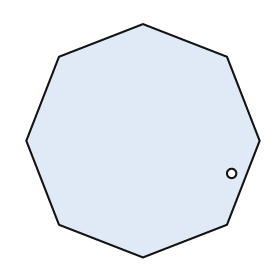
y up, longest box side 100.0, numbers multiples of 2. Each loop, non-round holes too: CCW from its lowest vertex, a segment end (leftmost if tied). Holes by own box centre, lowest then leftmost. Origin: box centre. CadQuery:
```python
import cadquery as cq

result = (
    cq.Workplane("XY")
    .moveTo(0.0, -50.0)
    .lineTo(36.0, -36.0)
    .lineTo(50.0, 0.0)
    .lineTo(36.0, 36.0)
    .lineTo(0.0, 50.0)
    .lineTo(-36.0, 36.0)
    .lineTo(-50.0, 0.0)
    .lineTo(-36.0, -36.0)
    .close()
    .moveTo(38.0, -14.0)
    .circle(2.0)
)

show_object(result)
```